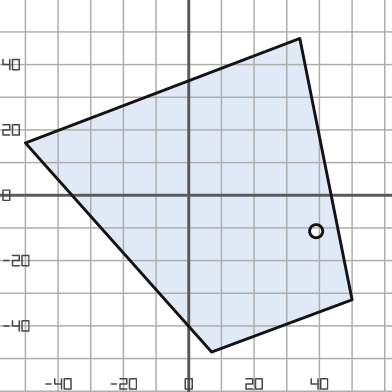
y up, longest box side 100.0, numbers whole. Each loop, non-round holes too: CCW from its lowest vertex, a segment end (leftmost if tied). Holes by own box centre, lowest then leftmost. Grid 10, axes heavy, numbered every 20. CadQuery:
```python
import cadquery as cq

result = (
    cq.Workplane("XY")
    .moveTo(7.0, -48.0)
    .lineTo(50.0, -32.0)
    .lineTo(34.0, 48.0)
    .lineTo(-50.0, 16.0)
    .close()
    .moveTo(39.0, -11.0)
    .circle(2.0)
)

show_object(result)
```